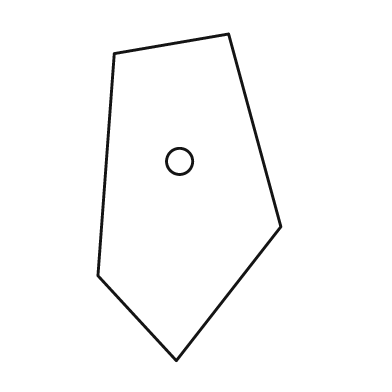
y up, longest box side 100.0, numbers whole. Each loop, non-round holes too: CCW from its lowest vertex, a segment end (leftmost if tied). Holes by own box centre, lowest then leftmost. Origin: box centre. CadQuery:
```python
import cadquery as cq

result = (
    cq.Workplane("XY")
    .moveTo(-4.0, -50.0)
    .lineTo(28.0, -9.0)
    .lineTo(12.0, 50.0)
    .lineTo(-23.0, 44.0)
    .lineTo(-28.0, -24.0)
    .close()
    .moveTo(-3.0, 11.0)
    .circle(4.0)
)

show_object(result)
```